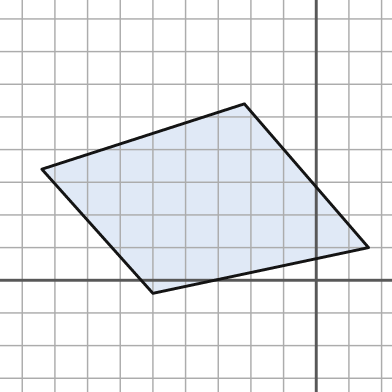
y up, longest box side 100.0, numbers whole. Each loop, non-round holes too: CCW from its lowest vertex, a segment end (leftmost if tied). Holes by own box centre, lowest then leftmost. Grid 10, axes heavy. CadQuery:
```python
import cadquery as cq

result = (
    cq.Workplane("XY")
    .moveTo(-50.0, -4.0)
    .lineTo(16.0, 10.0)
    .lineTo(-22.0, 54.0)
    .lineTo(-84.0, 34.0)
    .close()
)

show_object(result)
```